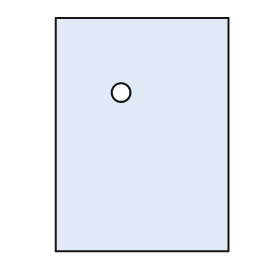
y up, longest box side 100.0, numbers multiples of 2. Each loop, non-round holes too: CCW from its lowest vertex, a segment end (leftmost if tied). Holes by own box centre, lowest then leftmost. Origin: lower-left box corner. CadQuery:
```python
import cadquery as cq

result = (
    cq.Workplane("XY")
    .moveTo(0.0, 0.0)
    .lineTo(74.0, 0.0)
    .lineTo(74.0, 100.0)
    .lineTo(0.0, 100.0)
    .close()
    .moveTo(28.0, 68.0)
    .circle(4.0)
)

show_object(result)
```